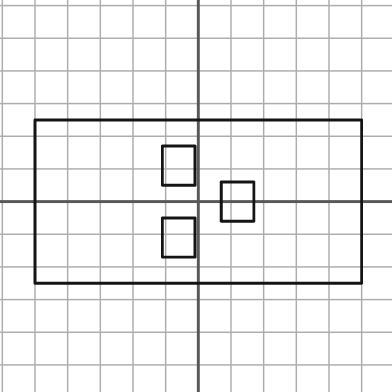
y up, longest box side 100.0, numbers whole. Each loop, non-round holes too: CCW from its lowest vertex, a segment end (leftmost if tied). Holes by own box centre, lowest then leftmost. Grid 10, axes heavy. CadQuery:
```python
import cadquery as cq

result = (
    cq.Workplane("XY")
    .moveTo(-50.0, -25.0)
    .lineTo(50.0, -25.0)
    .lineTo(50.0, 25.0)
    .lineTo(-50.0, 25.0)
    .close()
    .moveTo(-11.0, -17.0)
    .lineTo(-1.0, -17.0)
    .lineTo(-1.0, -5.0)
    .lineTo(-11.0, -5.0)
    .close()
    .moveTo(7.0, -6.0)
    .lineTo(17.0, -6.0)
    .lineTo(17.0, 6.0)
    .lineTo(7.0, 6.0)
    .close()
    .moveTo(-11.0, 5.0)
    .lineTo(-1.0, 5.0)
    .lineTo(-1.0, 17.0)
    .lineTo(-11.0, 17.0)
    .close()
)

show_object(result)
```